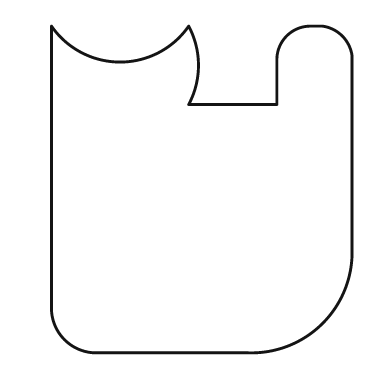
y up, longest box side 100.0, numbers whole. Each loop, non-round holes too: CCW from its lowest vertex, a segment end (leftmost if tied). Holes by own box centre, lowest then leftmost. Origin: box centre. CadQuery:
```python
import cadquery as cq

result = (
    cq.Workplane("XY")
    .moveTo(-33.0, -50.0)
    .lineTo(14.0, -50.0)
    .threePointArc((37.0, -41.0), (46.0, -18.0))
    .lineTo(46.0, 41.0)
    .threePointArc((43.0, 47.0), (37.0, 50.0))
    .lineTo(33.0, 50.0)
    .threePointArc((26.0, 47.0), (23.0, 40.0))
    .lineTo(23.0, 26.0)
    .lineTo(-4.0, 26.0)
    .threePointArc((-1.0, 38.0), (-4.0, 50.0))
    .threePointArc((-25.0, 39.0), (-46.0, 50.0))
    .lineTo(-46.0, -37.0)
    .threePointArc((-42.0, -46.0), (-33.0, -50.0))
    .close()
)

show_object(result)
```